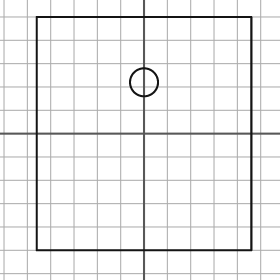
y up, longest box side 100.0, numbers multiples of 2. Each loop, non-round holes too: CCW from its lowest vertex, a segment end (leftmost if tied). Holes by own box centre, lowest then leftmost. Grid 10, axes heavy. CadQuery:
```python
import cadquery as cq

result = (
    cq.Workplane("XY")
    .moveTo(-46.0, -50.0)
    .lineTo(46.0, -50.0)
    .lineTo(46.0, 50.0)
    .lineTo(-46.0, 50.0)
    .close()
    .moveTo(0.0, 22.0)
    .circle(6.0)
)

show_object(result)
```